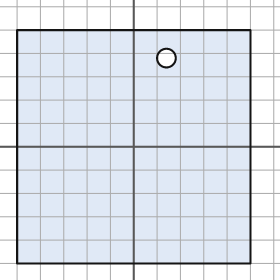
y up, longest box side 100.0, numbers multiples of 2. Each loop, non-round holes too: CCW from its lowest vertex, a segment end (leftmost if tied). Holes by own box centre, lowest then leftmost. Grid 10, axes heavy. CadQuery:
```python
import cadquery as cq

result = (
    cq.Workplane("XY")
    .moveTo(-50.0, -50.0)
    .lineTo(50.0, -50.0)
    .lineTo(50.0, 50.0)
    .lineTo(-50.0, 50.0)
    .close()
    .moveTo(14.0, 38.0)
    .circle(4.0)
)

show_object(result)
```